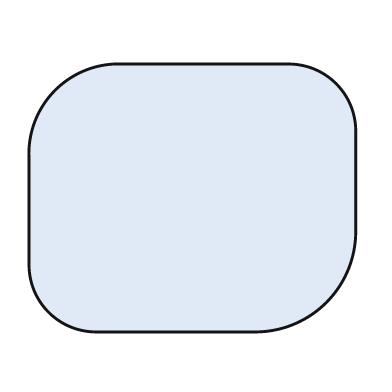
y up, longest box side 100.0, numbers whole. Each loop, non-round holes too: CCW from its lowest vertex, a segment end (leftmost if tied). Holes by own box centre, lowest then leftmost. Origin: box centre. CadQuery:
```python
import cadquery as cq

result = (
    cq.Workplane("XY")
    .moveTo(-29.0, -41.0)
    .lineTo(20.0, -41.0)
    .threePointArc((41.0, -32.0), (50.0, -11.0))
    .lineTo(50.0, 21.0)
    .threePointArc((44.0, 35.0), (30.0, 41.0))
    .lineTo(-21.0, 41.0)
    .threePointArc((-42.0, 33.0), (-50.0, 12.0))
    .lineTo(-50.0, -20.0)
    .threePointArc((-44.0, -35.0), (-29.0, -41.0))
    .close()
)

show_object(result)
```